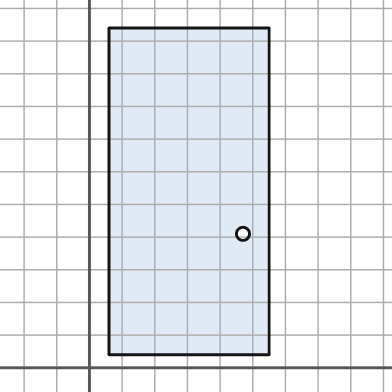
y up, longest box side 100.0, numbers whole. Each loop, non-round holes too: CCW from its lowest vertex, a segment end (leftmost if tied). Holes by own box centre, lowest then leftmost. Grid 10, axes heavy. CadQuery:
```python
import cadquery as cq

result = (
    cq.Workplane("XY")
    .moveTo(6.0, 4.0)
    .lineTo(55.0, 4.0)
    .lineTo(55.0, 104.0)
    .lineTo(6.0, 104.0)
    .close()
    .moveTo(47.0, 41.0)
    .circle(2.0)
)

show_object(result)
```